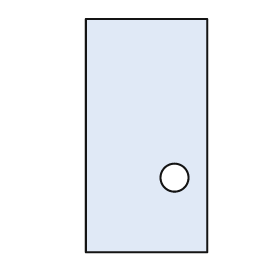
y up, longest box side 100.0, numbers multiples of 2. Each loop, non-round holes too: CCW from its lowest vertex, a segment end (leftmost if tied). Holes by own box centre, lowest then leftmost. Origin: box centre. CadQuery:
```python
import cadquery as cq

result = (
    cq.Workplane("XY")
    .moveTo(-26.0, -50.0)
    .lineTo(26.0, -50.0)
    .lineTo(26.0, 50.0)
    .lineTo(-26.0, 50.0)
    .close()
    .moveTo(12.0, -18.0)
    .circle(6.0)
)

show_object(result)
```